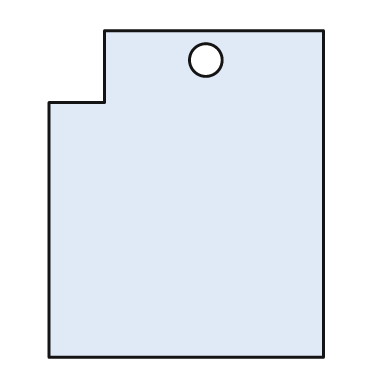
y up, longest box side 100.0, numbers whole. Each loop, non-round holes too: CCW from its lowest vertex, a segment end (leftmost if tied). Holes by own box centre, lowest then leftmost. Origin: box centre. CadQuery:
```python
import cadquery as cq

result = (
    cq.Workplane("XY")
    .moveTo(-42.0, -50.0)
    .lineTo(42.0, -50.0)
    .lineTo(42.0, 50.0)
    .lineTo(-25.0, 50.0)
    .lineTo(-25.0, 28.0)
    .lineTo(-42.0, 28.0)
    .close()
    .moveTo(6.0, 41.0)
    .circle(5.0)
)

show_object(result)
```